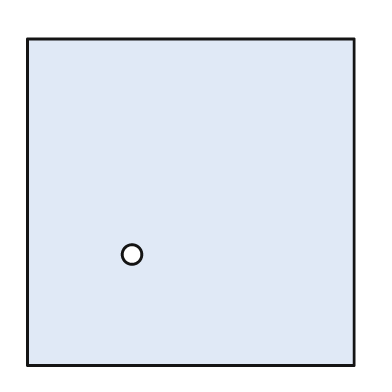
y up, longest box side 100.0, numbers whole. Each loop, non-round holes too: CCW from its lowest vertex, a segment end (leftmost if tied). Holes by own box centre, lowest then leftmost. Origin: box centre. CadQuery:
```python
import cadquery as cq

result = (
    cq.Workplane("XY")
    .moveTo(-50.0, -50.0)
    .lineTo(50.0, -50.0)
    .lineTo(50.0, 50.0)
    .lineTo(-50.0, 50.0)
    .close()
    .moveTo(-18.0, -16.0)
    .circle(3.0)
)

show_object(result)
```